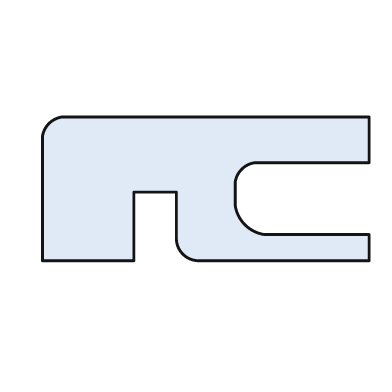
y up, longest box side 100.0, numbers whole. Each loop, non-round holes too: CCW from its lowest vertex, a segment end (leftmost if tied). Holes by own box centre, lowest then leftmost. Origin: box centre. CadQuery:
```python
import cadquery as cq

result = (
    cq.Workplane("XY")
    .moveTo(-50.0, -22.0)
    .lineTo(-22.0, -22.0)
    .lineTo(-22.0, -1.0)
    .lineTo(-9.0, -1.0)
    .lineTo(-9.0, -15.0)
    .threePointArc((-7.0, -20.0), (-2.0, -22.0))
    .lineTo(50.0, -22.0)
    .lineTo(50.0, -14.0)
    .lineTo(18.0, -14.0)
    .threePointArc((12.0, -11.0), (9.0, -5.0))
    .lineTo(9.0, 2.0)
    .threePointArc((11.0, 6.0), (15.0, 8.0))
    .lineTo(50.0, 8.0)
    .lineTo(50.0, 22.0)
    .lineTo(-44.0, 22.0)
    .threePointArc((-48.0, 20.0), (-50.0, 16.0))
    .close()
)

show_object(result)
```